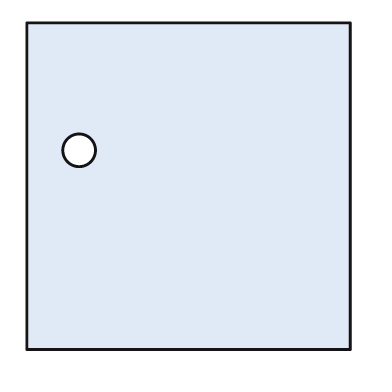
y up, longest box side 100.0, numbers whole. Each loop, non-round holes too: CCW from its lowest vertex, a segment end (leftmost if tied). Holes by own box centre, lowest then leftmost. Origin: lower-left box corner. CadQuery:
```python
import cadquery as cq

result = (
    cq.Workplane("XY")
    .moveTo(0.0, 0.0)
    .lineTo(99.0, 0.0)
    .lineTo(99.0, 100.0)
    .lineTo(0.0, 100.0)
    .close()
    .moveTo(16.0, 61.0)
    .circle(5.0)
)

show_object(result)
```